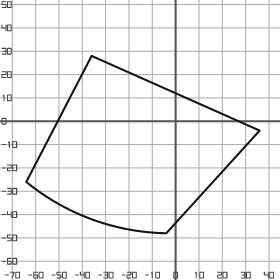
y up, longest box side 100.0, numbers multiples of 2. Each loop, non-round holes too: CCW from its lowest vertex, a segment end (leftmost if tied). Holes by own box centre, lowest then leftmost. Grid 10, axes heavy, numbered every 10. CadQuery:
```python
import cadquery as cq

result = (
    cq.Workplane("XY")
    .moveTo(-4.0, -48.0)
    .lineTo(36.0, -4.0)
    .lineTo(-36.0, 28.0)
    .lineTo(-64.0, -26.0)
    .threePointArc((-36.0, -42.0), (-4.0, -48.0))
    .close()
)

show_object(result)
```